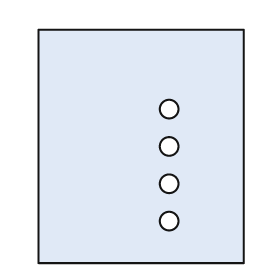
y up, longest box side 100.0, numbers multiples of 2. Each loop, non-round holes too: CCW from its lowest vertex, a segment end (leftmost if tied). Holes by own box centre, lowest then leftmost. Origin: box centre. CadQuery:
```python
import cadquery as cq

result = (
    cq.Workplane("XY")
    .moveTo(-44.0, -50.0)
    .lineTo(44.0, -50.0)
    .lineTo(44.0, 50.0)
    .lineTo(-44.0, 50.0)
    .close()
    .moveTo(12.0, -32.0)
    .circle(4.0)
    .moveTo(12.0, -16.0)
    .circle(4.0)
    .moveTo(12.0, 0.0)
    .circle(4.0)
    .moveTo(12.0, 16.0)
    .circle(4.0)
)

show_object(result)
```